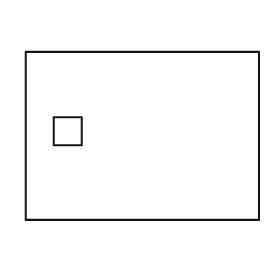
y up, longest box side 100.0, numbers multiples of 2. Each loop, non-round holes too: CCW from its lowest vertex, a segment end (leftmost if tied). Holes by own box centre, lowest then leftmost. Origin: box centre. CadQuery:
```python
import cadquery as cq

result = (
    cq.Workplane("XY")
    .moveTo(-50.0, -36.0)
    .lineTo(50.0, -36.0)
    .lineTo(50.0, 36.0)
    .lineTo(-50.0, 36.0)
    .close()
    .moveTo(-38.0, -4.0)
    .lineTo(-26.0, -4.0)
    .lineTo(-26.0, 8.0)
    .lineTo(-38.0, 8.0)
    .close()
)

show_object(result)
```